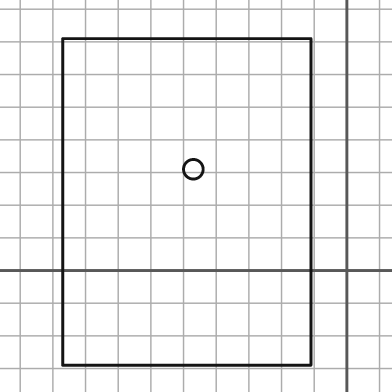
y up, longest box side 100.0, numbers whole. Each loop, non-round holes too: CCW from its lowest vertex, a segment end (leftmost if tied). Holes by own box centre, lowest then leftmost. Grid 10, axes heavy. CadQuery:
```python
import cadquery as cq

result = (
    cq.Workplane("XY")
    .moveTo(-87.0, -29.0)
    .lineTo(-11.0, -29.0)
    .lineTo(-11.0, 71.0)
    .lineTo(-87.0, 71.0)
    .close()
    .moveTo(-47.0, 31.0)
    .circle(3.0)
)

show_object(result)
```